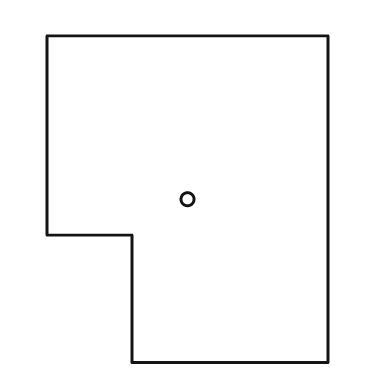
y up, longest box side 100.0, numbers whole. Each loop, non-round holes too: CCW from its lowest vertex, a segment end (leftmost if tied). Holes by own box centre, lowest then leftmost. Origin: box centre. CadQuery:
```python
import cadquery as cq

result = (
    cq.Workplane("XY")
    .moveTo(-17.0, -50.0)
    .lineTo(43.0, -50.0)
    .lineTo(43.0, 50.0)
    .lineTo(-43.0, 50.0)
    .lineTo(-43.0, -11.0)
    .lineTo(-17.0, -11.0)
    .close()
    .moveTo(0.0, 0.0)
    .circle(2.0)
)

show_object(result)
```